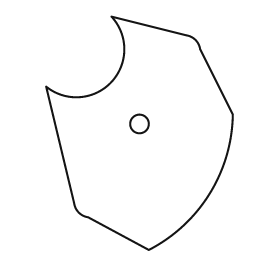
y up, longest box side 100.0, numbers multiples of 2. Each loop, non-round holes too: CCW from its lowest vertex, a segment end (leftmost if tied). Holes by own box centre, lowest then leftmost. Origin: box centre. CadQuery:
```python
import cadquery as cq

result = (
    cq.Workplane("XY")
    .moveTo(4.0, -50.0)
    .threePointArc((30.0, -26.0), (40.0, 8.0))
    .lineTo(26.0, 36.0)
    .threePointArc((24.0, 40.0), (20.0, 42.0))
    .lineTo(-12.0, 50.0)
    .threePointArc((-12.0, 22.0), (-40.0, 20.0))
    .lineTo(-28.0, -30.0)
    .threePointArc((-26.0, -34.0), (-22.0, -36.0))
    .close()
    .moveTo(0.0, 4.0)
    .circle(4.0)
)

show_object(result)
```